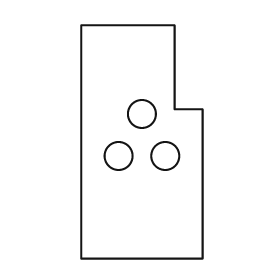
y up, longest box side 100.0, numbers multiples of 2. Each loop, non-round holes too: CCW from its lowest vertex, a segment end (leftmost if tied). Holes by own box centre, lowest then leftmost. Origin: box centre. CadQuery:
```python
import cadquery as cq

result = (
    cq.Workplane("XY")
    .moveTo(-26.0, -50.0)
    .lineTo(26.0, -50.0)
    .lineTo(26.0, 14.0)
    .lineTo(14.0, 14.0)
    .lineTo(14.0, 50.0)
    .lineTo(-26.0, 50.0)
    .close()
    .moveTo(-10.0, -6.0)
    .circle(6.0)
    .moveTo(10.0, -6.0)
    .circle(6.0)
    .moveTo(0.0, 12.0)
    .circle(6.0)
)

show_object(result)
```